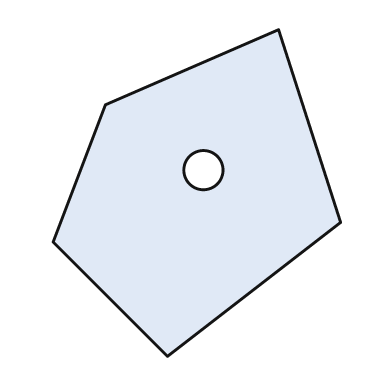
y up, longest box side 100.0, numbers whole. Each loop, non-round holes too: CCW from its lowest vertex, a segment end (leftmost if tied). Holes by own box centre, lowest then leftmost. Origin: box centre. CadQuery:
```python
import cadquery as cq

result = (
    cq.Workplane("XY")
    .moveTo(-9.0, -50.0)
    .lineTo(44.0, -9.0)
    .lineTo(25.0, 50.0)
    .lineTo(-28.0, 27.0)
    .lineTo(-44.0, -15.0)
    .close()
    .moveTo(2.0, 7.0)
    .circle(6.0)
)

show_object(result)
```